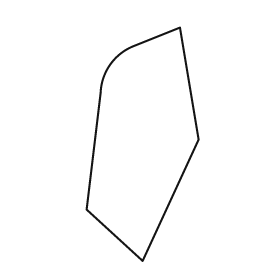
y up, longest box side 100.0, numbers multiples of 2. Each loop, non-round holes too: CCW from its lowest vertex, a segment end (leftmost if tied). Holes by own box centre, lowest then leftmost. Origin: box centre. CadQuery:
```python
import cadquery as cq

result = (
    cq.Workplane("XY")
    .moveTo(0.0, -50.0)
    .lineTo(24.0, 2.0)
    .lineTo(16.0, 50.0)
    .lineTo(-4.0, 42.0)
    .threePointArc((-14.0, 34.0), (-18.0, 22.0))
    .lineTo(-24.0, -28.0)
    .close()
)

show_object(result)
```